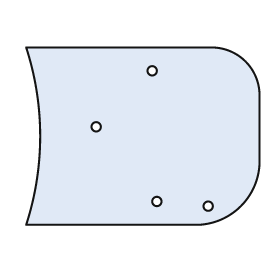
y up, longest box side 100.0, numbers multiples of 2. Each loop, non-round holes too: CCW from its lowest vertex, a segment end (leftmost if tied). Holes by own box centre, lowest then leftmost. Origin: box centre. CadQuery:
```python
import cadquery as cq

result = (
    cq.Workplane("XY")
    .moveTo(-50.0, -38.0)
    .lineTo(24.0, -38.0)
    .threePointArc((42.0, -30.0), (50.0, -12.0))
    .lineTo(50.0, 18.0)
    .threePointArc((44.0, 32.0), (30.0, 38.0))
    .lineTo(-50.0, 38.0)
    .threePointArc((-44.0, 0.0), (-50.0, -38.0))
    .close()
    .moveTo(28.0, -30.0)
    .circle(2.0)
    .moveTo(6.0, -28.0)
    .circle(2.0)
    .moveTo(-20.0, 4.0)
    .circle(2.0)
    .moveTo(4.0, 28.0)
    .circle(2.0)
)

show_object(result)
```